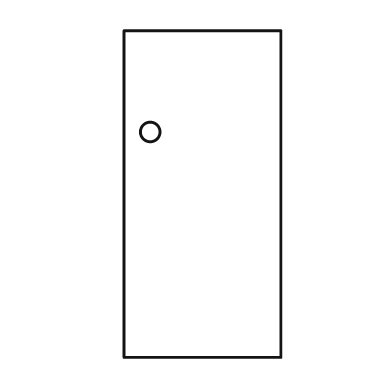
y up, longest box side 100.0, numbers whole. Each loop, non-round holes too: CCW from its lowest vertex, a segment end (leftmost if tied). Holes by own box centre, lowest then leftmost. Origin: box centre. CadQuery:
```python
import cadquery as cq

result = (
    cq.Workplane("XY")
    .moveTo(-24.0, -50.0)
    .lineTo(24.0, -50.0)
    .lineTo(24.0, 50.0)
    .lineTo(-24.0, 50.0)
    .close()
    .moveTo(-16.0, 19.0)
    .circle(3.0)
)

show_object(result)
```